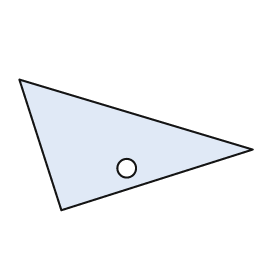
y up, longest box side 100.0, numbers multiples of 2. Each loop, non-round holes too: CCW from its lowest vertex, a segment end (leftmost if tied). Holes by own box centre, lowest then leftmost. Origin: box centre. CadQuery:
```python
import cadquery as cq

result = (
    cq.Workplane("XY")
    .moveTo(-32.0, -28.0)
    .lineTo(50.0, -2.0)
    .lineTo(-50.0, 28.0)
    .close()
    .moveTo(-4.0, -10.0)
    .circle(4.0)
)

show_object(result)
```